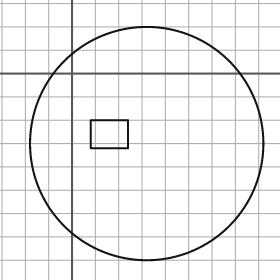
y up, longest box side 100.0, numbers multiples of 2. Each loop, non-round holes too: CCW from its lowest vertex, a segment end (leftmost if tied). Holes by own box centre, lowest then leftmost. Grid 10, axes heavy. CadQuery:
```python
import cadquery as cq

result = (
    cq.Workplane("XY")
    .moveTo(32.0, -30.0)
    .circle(50.0)
    .moveTo(8.0, -32.0)
    .lineTo(24.0, -32.0)
    .lineTo(24.0, -20.0)
    .lineTo(8.0, -20.0)
    .close()
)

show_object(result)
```